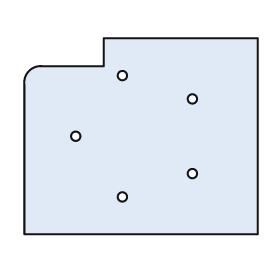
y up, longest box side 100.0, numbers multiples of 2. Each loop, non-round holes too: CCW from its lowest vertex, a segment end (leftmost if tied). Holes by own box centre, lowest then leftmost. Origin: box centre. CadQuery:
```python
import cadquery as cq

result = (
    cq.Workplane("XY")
    .moveTo(-50.0, -42.0)
    .lineTo(50.0, -42.0)
    .lineTo(50.0, 42.0)
    .lineTo(-16.0, 42.0)
    .lineTo(-16.0, 30.0)
    .lineTo(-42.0, 30.0)
    .threePointArc((-48.0, 28.0), (-50.0, 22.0))
    .close()
    .moveTo(-8.0, -26.0)
    .circle(2.0)
    .moveTo(22.0, -16.0)
    .circle(2.0)
    .moveTo(-28.0, 0.0)
    .circle(2.0)
    .moveTo(22.0, 16.0)
    .circle(2.0)
    .moveTo(-8.0, 26.0)
    .circle(2.0)
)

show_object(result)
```